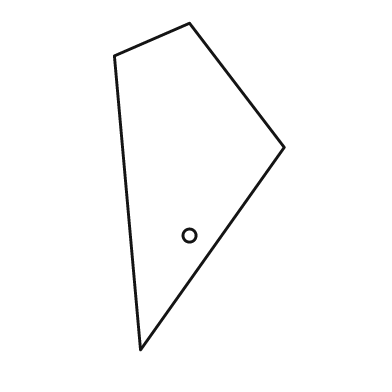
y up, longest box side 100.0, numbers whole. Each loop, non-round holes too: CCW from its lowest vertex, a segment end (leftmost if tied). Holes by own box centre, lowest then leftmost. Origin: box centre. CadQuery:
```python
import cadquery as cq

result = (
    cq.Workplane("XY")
    .moveTo(-18.0, -50.0)
    .lineTo(26.0, 12.0)
    .lineTo(-3.0, 50.0)
    .lineTo(-26.0, 40.0)
    .close()
    .moveTo(-3.0, -15.0)
    .circle(2.0)
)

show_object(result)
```